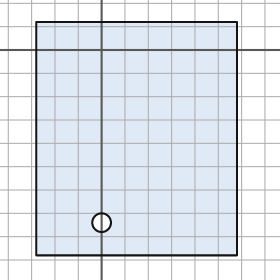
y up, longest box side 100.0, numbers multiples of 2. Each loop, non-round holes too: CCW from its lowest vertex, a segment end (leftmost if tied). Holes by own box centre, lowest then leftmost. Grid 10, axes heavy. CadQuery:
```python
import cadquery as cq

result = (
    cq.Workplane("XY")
    .moveTo(-28.0, -88.0)
    .lineTo(58.0, -88.0)
    .lineTo(58.0, 12.0)
    .lineTo(-28.0, 12.0)
    .close()
    .moveTo(0.0, -74.0)
    .circle(4.0)
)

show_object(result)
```